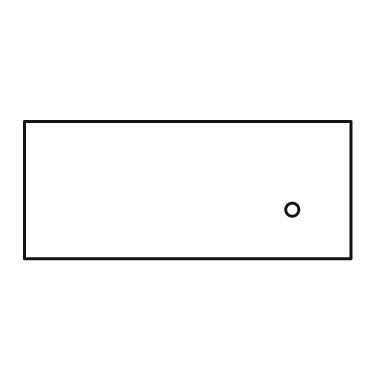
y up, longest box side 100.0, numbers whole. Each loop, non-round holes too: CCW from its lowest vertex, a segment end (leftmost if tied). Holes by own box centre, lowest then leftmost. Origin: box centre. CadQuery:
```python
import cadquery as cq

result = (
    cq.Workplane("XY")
    .moveTo(-50.0, -21.0)
    .lineTo(50.0, -21.0)
    .lineTo(50.0, 21.0)
    .lineTo(-50.0, 21.0)
    .close()
    .moveTo(32.0, -6.0)
    .circle(2.0)
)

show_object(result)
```